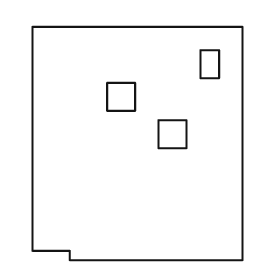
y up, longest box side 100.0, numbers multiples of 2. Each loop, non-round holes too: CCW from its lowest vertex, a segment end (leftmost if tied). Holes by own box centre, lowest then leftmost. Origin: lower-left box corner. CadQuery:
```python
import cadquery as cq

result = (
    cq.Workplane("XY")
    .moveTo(16.0, 0.0)
    .lineTo(90.0, 0.0)
    .lineTo(90.0, 100.0)
    .lineTo(0.0, 100.0)
    .lineTo(0.0, 4.0)
    .lineTo(16.0, 4.0)
    .close()
    .moveTo(54.0, 48.0)
    .lineTo(66.0, 48.0)
    .lineTo(66.0, 60.0)
    .lineTo(54.0, 60.0)
    .close()
    .moveTo(32.0, 64.0)
    .lineTo(44.0, 64.0)
    .lineTo(44.0, 76.0)
    .lineTo(32.0, 76.0)
    .close()
    .moveTo(72.0, 78.0)
    .lineTo(80.0, 78.0)
    .lineTo(80.0, 90.0)
    .lineTo(72.0, 90.0)
    .close()
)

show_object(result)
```